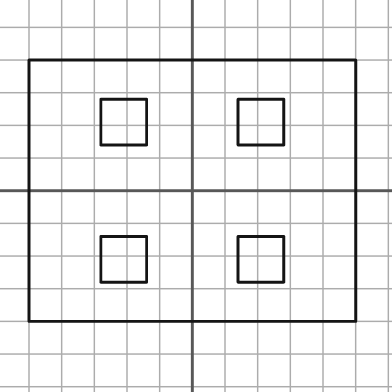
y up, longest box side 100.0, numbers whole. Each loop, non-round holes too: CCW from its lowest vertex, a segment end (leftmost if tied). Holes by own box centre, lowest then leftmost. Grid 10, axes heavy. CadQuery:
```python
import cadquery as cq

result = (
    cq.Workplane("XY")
    .moveTo(-50.0, -40.0)
    .lineTo(50.0, -40.0)
    .lineTo(50.0, 40.0)
    .lineTo(-50.0, 40.0)
    .close()
    .moveTo(-28.0, -28.0)
    .lineTo(-14.0, -28.0)
    .lineTo(-14.0, -14.0)
    .lineTo(-28.0, -14.0)
    .close()
    .moveTo(14.0, -28.0)
    .lineTo(28.0, -28.0)
    .lineTo(28.0, -14.0)
    .lineTo(14.0, -14.0)
    .close()
    .moveTo(-28.0, 14.0)
    .lineTo(-14.0, 14.0)
    .lineTo(-14.0, 28.0)
    .lineTo(-28.0, 28.0)
    .close()
    .moveTo(14.0, 14.0)
    .lineTo(28.0, 14.0)
    .lineTo(28.0, 28.0)
    .lineTo(14.0, 28.0)
    .close()
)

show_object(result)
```